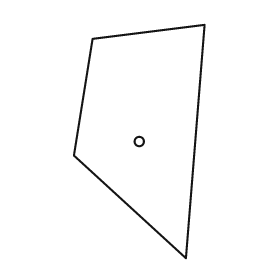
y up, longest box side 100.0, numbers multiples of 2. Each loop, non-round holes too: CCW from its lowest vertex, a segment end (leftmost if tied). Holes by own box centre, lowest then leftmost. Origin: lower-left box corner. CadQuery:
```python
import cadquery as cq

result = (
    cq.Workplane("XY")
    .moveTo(48.0, 0.0)
    .lineTo(56.0, 100.0)
    .lineTo(8.0, 94.0)
    .lineTo(0.0, 44.0)
    .close()
    .moveTo(28.0, 50.0)
    .circle(2.0)
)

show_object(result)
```